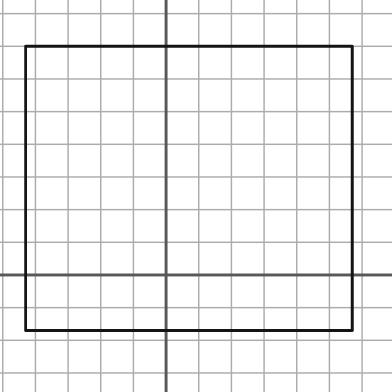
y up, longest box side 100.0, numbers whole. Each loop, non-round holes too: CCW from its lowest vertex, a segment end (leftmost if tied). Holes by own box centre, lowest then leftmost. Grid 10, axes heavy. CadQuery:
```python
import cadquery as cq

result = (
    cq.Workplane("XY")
    .moveTo(-43.0, -17.0)
    .lineTo(57.0, -17.0)
    .lineTo(57.0, 70.0)
    .lineTo(-43.0, 70.0)
    .close()
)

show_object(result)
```